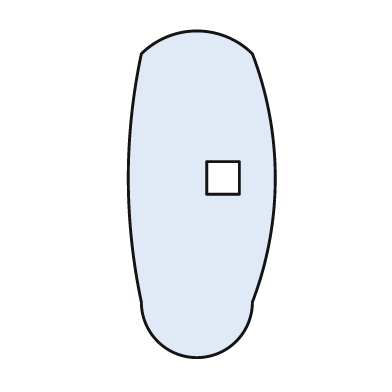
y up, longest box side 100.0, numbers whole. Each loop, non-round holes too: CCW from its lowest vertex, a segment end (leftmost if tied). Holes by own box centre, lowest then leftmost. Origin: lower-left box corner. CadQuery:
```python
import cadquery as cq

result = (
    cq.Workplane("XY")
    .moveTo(4.0, 17.0)
    .threePointArc((21.0, 0.0), (38.0, 17.0))
    .threePointArc((45.0, 55.0), (38.0, 93.0))
    .threePointArc((21.0, 100.0), (4.0, 93.0))
    .threePointArc((0.0, 55.0), (4.0, 17.0))
    .close()
    .moveTo(24.0, 50.0)
    .lineTo(34.0, 50.0)
    .lineTo(34.0, 60.0)
    .lineTo(24.0, 60.0)
    .close()
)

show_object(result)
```